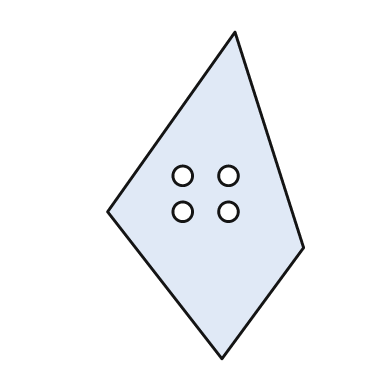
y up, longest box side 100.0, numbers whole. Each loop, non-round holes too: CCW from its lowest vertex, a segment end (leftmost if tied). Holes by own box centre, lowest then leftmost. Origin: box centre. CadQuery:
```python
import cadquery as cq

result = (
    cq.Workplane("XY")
    .moveTo(5.0, -50.0)
    .lineTo(30.0, -16.0)
    .lineTo(9.0, 50.0)
    .lineTo(-30.0, -5.0)
    .close()
    .moveTo(-7.0, -5.0)
    .circle(3.0)
    .moveTo(7.0, -5.0)
    .circle(3.0)
    .moveTo(-7.0, 6.0)
    .circle(3.0)
    .moveTo(7.0, 6.0)
    .circle(3.0)
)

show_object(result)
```